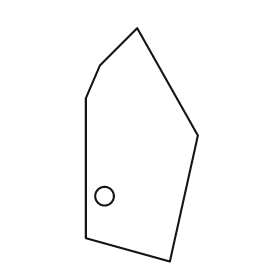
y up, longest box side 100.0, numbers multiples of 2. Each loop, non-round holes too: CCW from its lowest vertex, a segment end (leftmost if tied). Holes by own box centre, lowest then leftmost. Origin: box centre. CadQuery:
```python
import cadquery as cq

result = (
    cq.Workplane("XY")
    .moveTo(12.0, -50.0)
    .lineTo(24.0, 4.0)
    .lineTo(-2.0, 50.0)
    .lineTo(-18.0, 34.0)
    .lineTo(-24.0, 20.0)
    .lineTo(-24.0, -40.0)
    .close()
    .moveTo(-16.0, -22.0)
    .circle(4.0)
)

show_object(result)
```